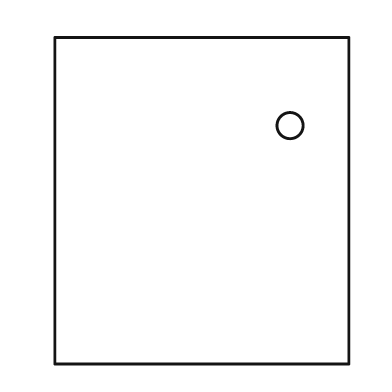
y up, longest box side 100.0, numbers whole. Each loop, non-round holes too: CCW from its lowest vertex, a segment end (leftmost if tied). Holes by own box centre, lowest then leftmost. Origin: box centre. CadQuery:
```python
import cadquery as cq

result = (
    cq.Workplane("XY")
    .moveTo(-45.0, -50.0)
    .lineTo(45.0, -50.0)
    .lineTo(45.0, 50.0)
    .lineTo(-45.0, 50.0)
    .close()
    .moveTo(27.0, 23.0)
    .circle(4.0)
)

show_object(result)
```